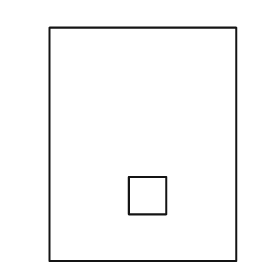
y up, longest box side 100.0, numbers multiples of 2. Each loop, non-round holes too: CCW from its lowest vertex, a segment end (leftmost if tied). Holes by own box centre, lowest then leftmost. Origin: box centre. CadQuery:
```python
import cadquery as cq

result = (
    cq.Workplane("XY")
    .moveTo(-40.0, -50.0)
    .lineTo(40.0, -50.0)
    .lineTo(40.0, 50.0)
    .lineTo(-40.0, 50.0)
    .close()
    .moveTo(-6.0, -30.0)
    .lineTo(10.0, -30.0)
    .lineTo(10.0, -14.0)
    .lineTo(-6.0, -14.0)
    .close()
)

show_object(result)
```